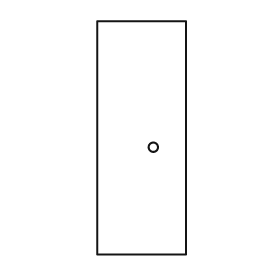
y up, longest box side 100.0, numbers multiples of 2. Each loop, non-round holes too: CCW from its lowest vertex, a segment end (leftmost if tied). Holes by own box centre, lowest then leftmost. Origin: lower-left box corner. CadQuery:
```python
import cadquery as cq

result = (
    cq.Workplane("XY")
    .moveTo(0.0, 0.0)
    .lineTo(38.0, 0.0)
    .lineTo(38.0, 100.0)
    .lineTo(0.0, 100.0)
    .close()
    .moveTo(24.0, 46.0)
    .circle(2.0)
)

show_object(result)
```